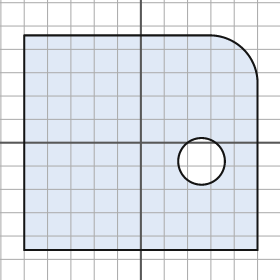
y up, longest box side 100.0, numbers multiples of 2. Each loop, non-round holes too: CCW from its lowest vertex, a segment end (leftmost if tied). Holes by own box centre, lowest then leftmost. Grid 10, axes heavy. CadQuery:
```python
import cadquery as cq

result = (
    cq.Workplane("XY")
    .moveTo(-50.0, -46.0)
    .lineTo(50.0, -46.0)
    .lineTo(50.0, 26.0)
    .threePointArc((44.0, 40.0), (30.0, 46.0))
    .lineTo(-50.0, 46.0)
    .close()
    .moveTo(26.0, -8.0)
    .circle(10.0)
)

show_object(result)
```